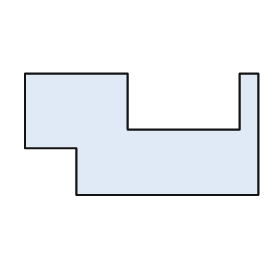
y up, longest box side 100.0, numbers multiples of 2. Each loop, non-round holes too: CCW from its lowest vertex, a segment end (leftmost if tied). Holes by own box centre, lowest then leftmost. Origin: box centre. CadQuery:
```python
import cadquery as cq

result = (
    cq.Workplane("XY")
    .moveTo(-28.0, -26.0)
    .lineTo(50.0, -26.0)
    .lineTo(50.0, 26.0)
    .lineTo(42.0, 26.0)
    .lineTo(42.0, 2.0)
    .lineTo(-6.0, 2.0)
    .lineTo(-6.0, 26.0)
    .lineTo(-50.0, 26.0)
    .lineTo(-50.0, -6.0)
    .lineTo(-28.0, -6.0)
    .close()
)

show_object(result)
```